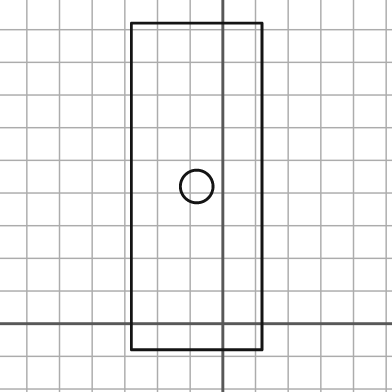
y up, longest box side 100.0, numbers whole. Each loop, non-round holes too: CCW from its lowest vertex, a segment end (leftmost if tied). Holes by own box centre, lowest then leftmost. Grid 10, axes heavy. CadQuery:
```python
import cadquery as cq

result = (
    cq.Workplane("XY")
    .moveTo(-28.0, -8.0)
    .lineTo(12.0, -8.0)
    .lineTo(12.0, 92.0)
    .lineTo(-28.0, 92.0)
    .close()
    .moveTo(-8.0, 42.0)
    .circle(5.0)
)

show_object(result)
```